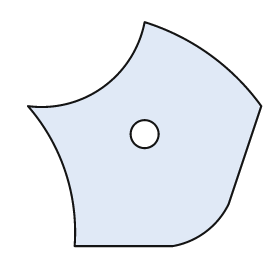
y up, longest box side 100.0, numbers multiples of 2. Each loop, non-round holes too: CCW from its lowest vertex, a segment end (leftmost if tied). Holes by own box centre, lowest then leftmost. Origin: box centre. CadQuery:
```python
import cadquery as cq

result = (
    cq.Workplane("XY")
    .moveTo(-30.0, -48.0)
    .lineTo(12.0, -48.0)
    .threePointArc((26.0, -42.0), (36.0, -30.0))
    .lineTo(50.0, 12.0)
    .threePointArc((28.0, 34.0), (0.0, 48.0))
    .threePointArc((-18.0, 20.0), (-50.0, 12.0))
    .threePointArc((-34.0, -16.0), (-30.0, -48.0))
    .close()
    .moveTo(0.0, 0.0)
    .circle(6.0)
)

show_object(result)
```